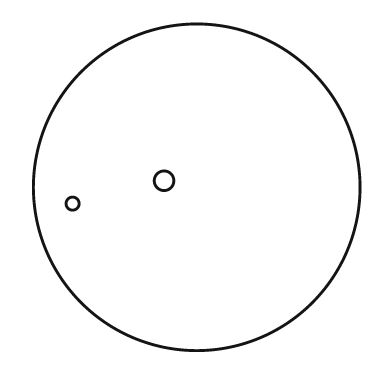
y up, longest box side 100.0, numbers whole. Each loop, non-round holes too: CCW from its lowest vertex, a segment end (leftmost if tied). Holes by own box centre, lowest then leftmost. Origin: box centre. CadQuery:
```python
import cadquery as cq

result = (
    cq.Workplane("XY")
    .moveTo(0.0, 0.0)
    .circle(50.0)
    .moveTo(-38.0, -5.0)
    .circle(2.0)
    .moveTo(-10.0, 2.0)
    .circle(3.0)
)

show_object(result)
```